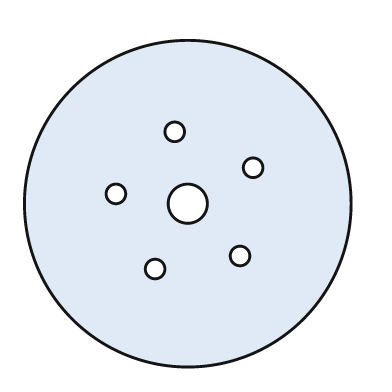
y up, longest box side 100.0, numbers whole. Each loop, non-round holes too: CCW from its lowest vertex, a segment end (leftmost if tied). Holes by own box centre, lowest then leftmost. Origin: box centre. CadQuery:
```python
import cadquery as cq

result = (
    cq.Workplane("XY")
    .moveTo(0.0, 0.0)
    .circle(50.0)
    .moveTo(-10.0, -20.0)
    .circle(3.0)
    .moveTo(16.0, -16.0)
    .circle(3.0)
    .moveTo(0.0, 0.0)
    .circle(6.0)
    .moveTo(-22.0, 3.0)
    .circle(3.0)
    .moveTo(20.0, 11.0)
    .circle(3.0)
    .moveTo(-4.0, 22.0)
    .circle(3.0)
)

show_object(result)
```